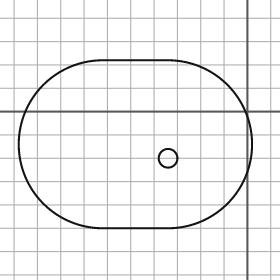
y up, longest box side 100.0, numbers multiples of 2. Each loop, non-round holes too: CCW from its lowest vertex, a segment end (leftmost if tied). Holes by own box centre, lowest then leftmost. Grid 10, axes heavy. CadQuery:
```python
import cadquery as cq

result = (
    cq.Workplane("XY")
    .moveTo(-62.0, -50.0)
    .lineTo(-34.0, -50.0)
    .threePointArc((2.0, -14.0), (-34.0, 22.0))
    .lineTo(-62.0, 22.0)
    .threePointArc((-98.0, -14.0), (-62.0, -50.0))
    .close()
    .moveTo(-34.0, -20.0)
    .circle(4.0)
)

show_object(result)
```